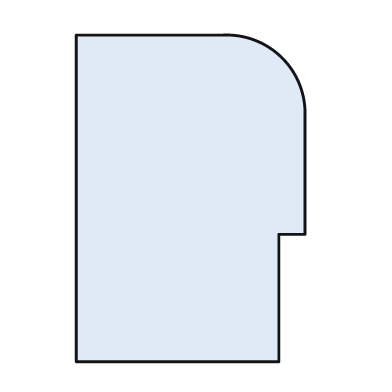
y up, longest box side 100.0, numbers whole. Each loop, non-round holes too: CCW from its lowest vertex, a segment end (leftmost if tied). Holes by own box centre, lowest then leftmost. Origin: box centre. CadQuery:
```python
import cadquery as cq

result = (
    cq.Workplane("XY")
    .moveTo(-35.0, -50.0)
    .lineTo(27.0, -50.0)
    .lineTo(27.0, -11.0)
    .lineTo(35.0, -11.0)
    .lineTo(35.0, 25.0)
    .threePointArc((28.0, 43.0), (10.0, 50.0))
    .lineTo(-35.0, 50.0)
    .close()
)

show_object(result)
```